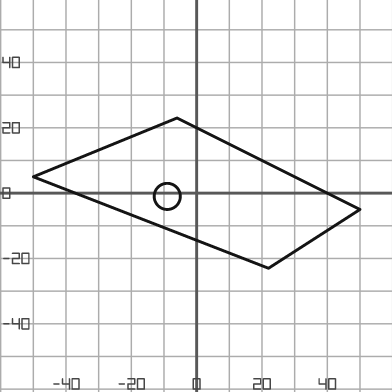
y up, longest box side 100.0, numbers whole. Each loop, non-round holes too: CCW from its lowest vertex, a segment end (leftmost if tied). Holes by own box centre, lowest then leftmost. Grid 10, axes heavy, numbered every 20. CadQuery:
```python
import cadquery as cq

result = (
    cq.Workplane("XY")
    .moveTo(22.0, -23.0)
    .lineTo(50.0, -5.0)
    .lineTo(-6.0, 23.0)
    .lineTo(-50.0, 5.0)
    .close()
    .moveTo(-9.0, -1.0)
    .circle(4.0)
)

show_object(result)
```